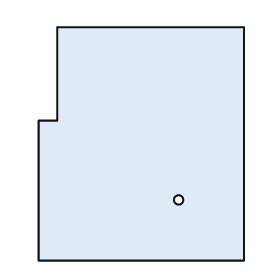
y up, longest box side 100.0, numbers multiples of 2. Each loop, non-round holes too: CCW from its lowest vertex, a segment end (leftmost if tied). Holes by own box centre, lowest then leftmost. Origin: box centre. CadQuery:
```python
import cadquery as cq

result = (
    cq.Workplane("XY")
    .moveTo(-44.0, -50.0)
    .lineTo(44.0, -50.0)
    .lineTo(44.0, 50.0)
    .lineTo(-36.0, 50.0)
    .lineTo(-36.0, 10.0)
    .lineTo(-44.0, 10.0)
    .close()
    .moveTo(16.0, -24.0)
    .circle(2.0)
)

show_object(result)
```